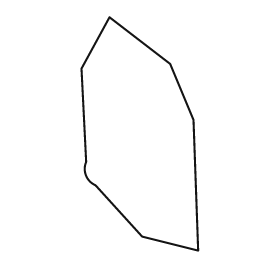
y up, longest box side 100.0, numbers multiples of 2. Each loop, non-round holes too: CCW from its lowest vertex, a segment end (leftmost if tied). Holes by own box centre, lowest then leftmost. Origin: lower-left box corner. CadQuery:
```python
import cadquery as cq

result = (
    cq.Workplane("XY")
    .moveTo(50.0, 0.0)
    .lineTo(48.0, 56.0)
    .lineTo(38.0, 80.0)
    .lineTo(12.0, 100.0)
    .lineTo(0.0, 78.0)
    .lineTo(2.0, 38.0)
    .threePointArc((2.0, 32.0), (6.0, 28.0))
    .lineTo(26.0, 6.0)
    .close()
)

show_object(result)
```